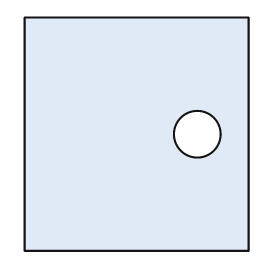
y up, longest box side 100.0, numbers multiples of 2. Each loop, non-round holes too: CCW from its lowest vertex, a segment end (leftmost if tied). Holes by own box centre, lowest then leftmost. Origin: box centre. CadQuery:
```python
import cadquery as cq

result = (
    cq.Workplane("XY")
    .moveTo(-48.0, -50.0)
    .lineTo(48.0, -50.0)
    .lineTo(48.0, 50.0)
    .lineTo(-48.0, 50.0)
    .close()
    .moveTo(26.0, 0.0)
    .circle(10.0)
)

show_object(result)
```